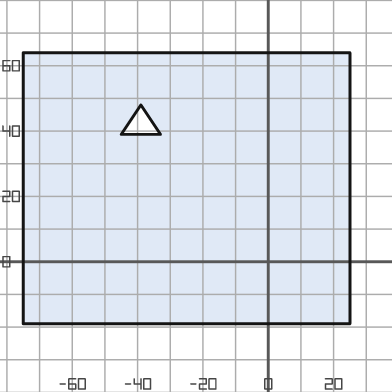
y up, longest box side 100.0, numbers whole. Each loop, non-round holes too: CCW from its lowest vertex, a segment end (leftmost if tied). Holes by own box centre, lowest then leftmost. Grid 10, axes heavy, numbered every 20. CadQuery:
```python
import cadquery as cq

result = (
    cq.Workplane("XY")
    .moveTo(-75.0, -19.0)
    .lineTo(25.0, -19.0)
    .lineTo(25.0, 64.0)
    .lineTo(-75.0, 64.0)
    .close()
    .moveTo(-45.0, 39.0)
    .lineTo(-33.0, 39.0)
    .lineTo(-39.0, 48.0)
    .close()
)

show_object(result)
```